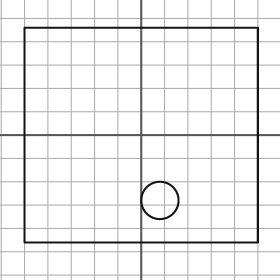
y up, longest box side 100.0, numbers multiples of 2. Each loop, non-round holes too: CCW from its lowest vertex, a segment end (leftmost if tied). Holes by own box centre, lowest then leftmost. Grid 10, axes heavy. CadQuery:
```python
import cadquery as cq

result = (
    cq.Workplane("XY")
    .moveTo(-50.0, -46.0)
    .lineTo(50.0, -46.0)
    .lineTo(50.0, 46.0)
    .lineTo(-50.0, 46.0)
    .close()
    .moveTo(8.0, -28.0)
    .circle(8.0)
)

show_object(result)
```